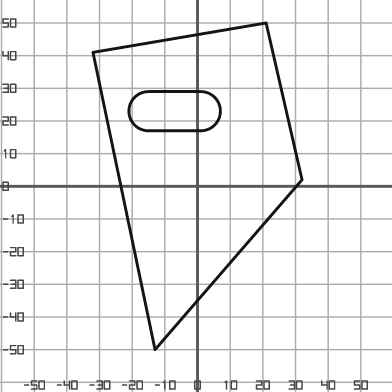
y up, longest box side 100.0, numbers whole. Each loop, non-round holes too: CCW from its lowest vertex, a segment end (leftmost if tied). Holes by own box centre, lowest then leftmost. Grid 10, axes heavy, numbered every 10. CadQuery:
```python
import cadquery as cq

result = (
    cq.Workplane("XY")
    .moveTo(-13.0, -50.0)
    .lineTo(32.0, 2.0)
    .lineTo(21.0, 50.0)
    .lineTo(-32.0, 41.0)
    .close()
    .moveTo(-15.0, 17.0)
    .lineTo(1.0, 17.0)
    .threePointArc((7.0, 23.0), (1.0, 29.0))
    .lineTo(-15.0, 29.0)
    .threePointArc((-21.0, 23.0), (-15.0, 17.0))
    .close()
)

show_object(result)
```